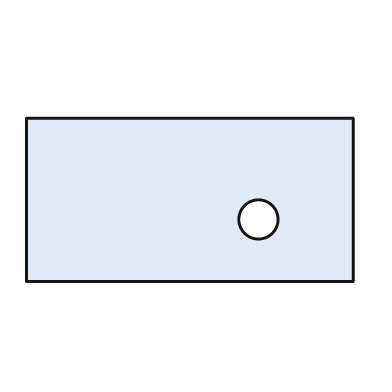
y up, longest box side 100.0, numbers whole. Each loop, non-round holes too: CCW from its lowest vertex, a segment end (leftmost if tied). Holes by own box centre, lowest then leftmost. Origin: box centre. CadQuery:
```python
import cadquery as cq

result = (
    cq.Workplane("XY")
    .moveTo(-50.0, -25.0)
    .lineTo(50.0, -25.0)
    .lineTo(50.0, 25.0)
    .lineTo(-50.0, 25.0)
    .close()
    .moveTo(21.0, -6.0)
    .circle(6.0)
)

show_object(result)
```